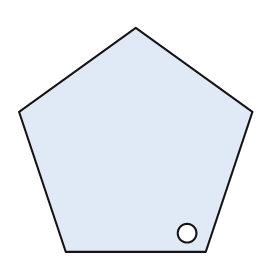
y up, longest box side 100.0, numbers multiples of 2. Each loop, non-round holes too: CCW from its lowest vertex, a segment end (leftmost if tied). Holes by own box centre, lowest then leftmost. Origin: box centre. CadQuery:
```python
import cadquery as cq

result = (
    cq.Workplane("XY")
    .moveTo(-30.0, -48.0)
    .lineTo(30.0, -48.0)
    .lineTo(50.0, 12.0)
    .lineTo(0.0, 48.0)
    .lineTo(-50.0, 12.0)
    .close()
    .moveTo(22.0, -40.0)
    .circle(4.0)
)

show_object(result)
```